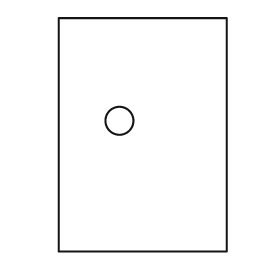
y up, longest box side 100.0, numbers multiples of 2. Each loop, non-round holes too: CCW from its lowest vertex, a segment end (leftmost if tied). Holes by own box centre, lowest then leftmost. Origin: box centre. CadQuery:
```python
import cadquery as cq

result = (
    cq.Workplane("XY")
    .moveTo(-36.0, -50.0)
    .lineTo(36.0, -50.0)
    .lineTo(36.0, 50.0)
    .lineTo(-36.0, 50.0)
    .close()
    .moveTo(-10.0, 6.0)
    .circle(6.0)
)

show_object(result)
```